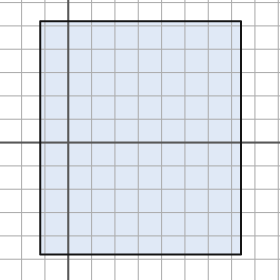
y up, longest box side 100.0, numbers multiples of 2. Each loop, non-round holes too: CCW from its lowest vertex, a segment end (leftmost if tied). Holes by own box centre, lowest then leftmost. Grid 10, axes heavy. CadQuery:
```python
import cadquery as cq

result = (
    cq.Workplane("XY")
    .moveTo(-12.0, -48.0)
    .lineTo(74.0, -48.0)
    .lineTo(74.0, 52.0)
    .lineTo(-12.0, 52.0)
    .close()
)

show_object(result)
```